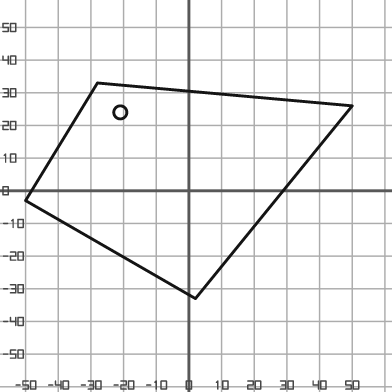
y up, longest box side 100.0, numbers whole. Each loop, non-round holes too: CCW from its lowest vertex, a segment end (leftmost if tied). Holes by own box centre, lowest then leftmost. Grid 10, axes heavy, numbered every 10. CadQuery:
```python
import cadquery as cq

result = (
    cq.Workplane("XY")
    .moveTo(2.0, -33.0)
    .lineTo(50.0, 26.0)
    .lineTo(-28.0, 33.0)
    .lineTo(-50.0, -3.0)
    .close()
    .moveTo(-21.0, 24.0)
    .circle(2.0)
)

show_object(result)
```